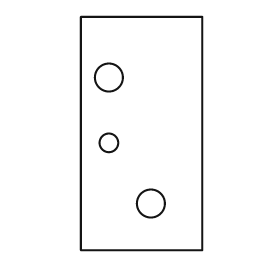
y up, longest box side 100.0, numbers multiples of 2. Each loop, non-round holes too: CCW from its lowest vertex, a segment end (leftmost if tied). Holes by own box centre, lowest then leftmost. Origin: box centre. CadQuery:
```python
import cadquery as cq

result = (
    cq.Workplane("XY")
    .moveTo(-26.0, -50.0)
    .lineTo(26.0, -50.0)
    .lineTo(26.0, 50.0)
    .lineTo(-26.0, 50.0)
    .close()
    .moveTo(4.0, -30.0)
    .circle(6.0)
    .moveTo(-14.0, -4.0)
    .circle(4.0)
    .moveTo(-14.0, 24.0)
    .circle(6.0)
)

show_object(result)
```